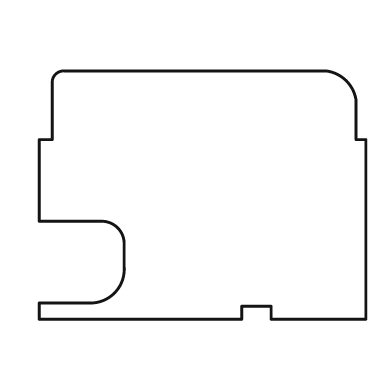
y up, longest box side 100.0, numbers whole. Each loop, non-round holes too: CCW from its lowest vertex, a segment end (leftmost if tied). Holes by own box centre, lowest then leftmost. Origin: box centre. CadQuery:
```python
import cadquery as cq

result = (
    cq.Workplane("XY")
    .moveTo(-50.0, -38.0)
    .lineTo(12.0, -38.0)
    .lineTo(12.0, -34.0)
    .lineTo(21.0, -34.0)
    .lineTo(21.0, -38.0)
    .lineTo(50.0, -38.0)
    .lineTo(50.0, 17.0)
    .lineTo(47.0, 17.0)
    .lineTo(47.0, 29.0)
    .threePointArc((44.0, 35.0), (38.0, 38.0))
    .lineTo(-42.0, 38.0)
    .threePointArc((-45.0, 37.0), (-46.0, 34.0))
    .lineTo(-46.0, 17.0)
    .lineTo(-50.0, 17.0)
    .lineTo(-50.0, -8.0)
    .lineTo(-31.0, -8.0)
    .threePointArc((-26.0, -10.0), (-24.0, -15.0))
    .lineTo(-24.0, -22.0)
    .threePointArc((-27.0, -30.0), (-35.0, -33.0))
    .lineTo(-50.0, -33.0)
    .close()
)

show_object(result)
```